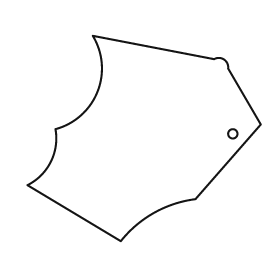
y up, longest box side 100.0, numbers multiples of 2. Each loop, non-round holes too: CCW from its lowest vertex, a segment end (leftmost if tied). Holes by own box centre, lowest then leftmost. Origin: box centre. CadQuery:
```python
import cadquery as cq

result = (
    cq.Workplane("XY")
    .moveTo(-10.0, -44.0)
    .threePointArc((4.0, -32.0), (22.0, -26.0))
    .lineTo(50.0, 6.0)
    .lineTo(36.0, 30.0)
    .threePointArc((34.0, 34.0), (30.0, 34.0))
    .lineTo(-22.0, 44.0)
    .threePointArc((-20.0, 20.0), (-38.0, 4.0))
    .threePointArc((-40.0, -10.0), (-50.0, -20.0))
    .close()
    .moveTo(38.0, 2.0)
    .circle(2.0)
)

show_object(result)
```